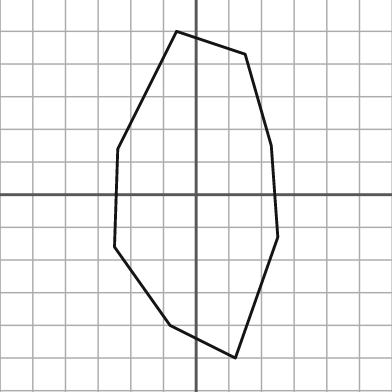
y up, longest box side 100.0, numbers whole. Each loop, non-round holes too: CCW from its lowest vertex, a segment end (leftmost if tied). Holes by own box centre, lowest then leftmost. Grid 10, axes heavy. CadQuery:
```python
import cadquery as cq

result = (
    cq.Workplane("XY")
    .moveTo(12.0, -50.0)
    .lineTo(25.0, -13.0)
    .lineTo(23.0, 15.0)
    .lineTo(15.0, 43.0)
    .lineTo(-6.0, 50.0)
    .lineTo(-24.0, 14.0)
    .lineTo(-25.0, -16.0)
    .lineTo(-8.0, -40.0)
    .close()
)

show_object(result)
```